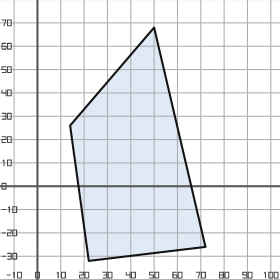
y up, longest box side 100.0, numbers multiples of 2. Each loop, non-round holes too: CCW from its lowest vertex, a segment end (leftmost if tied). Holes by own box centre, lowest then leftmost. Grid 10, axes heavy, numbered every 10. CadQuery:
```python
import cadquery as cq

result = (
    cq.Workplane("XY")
    .moveTo(22.0, -32.0)
    .lineTo(72.0, -26.0)
    .lineTo(50.0, 68.0)
    .lineTo(14.0, 26.0)
    .close()
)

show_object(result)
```